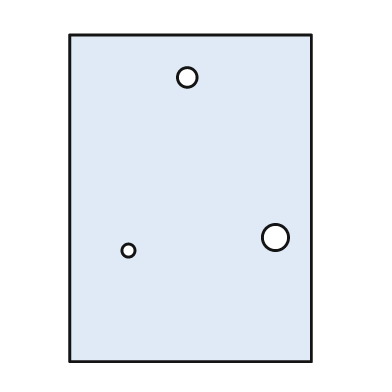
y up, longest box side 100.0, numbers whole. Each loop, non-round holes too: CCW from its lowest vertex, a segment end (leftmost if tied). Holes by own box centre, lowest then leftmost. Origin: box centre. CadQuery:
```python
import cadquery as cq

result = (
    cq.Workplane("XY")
    .moveTo(-37.0, -50.0)
    .lineTo(37.0, -50.0)
    .lineTo(37.0, 50.0)
    .lineTo(-37.0, 50.0)
    .close()
    .moveTo(-19.0, -16.0)
    .circle(2.0)
    .moveTo(26.0, -12.0)
    .circle(4.0)
    .moveTo(-1.0, 37.0)
    .circle(3.0)
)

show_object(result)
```